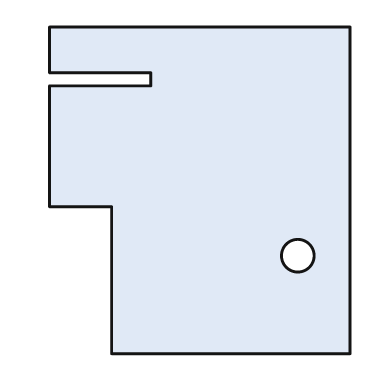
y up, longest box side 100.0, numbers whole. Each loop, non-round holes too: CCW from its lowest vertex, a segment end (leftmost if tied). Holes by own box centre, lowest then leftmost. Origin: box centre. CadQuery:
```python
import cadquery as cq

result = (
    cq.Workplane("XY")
    .moveTo(-27.0, -50.0)
    .lineTo(46.0, -50.0)
    .lineTo(46.0, 50.0)
    .lineTo(-46.0, 50.0)
    .lineTo(-46.0, 36.0)
    .lineTo(-15.0, 36.0)
    .lineTo(-15.0, 32.0)
    .lineTo(-46.0, 32.0)
    .lineTo(-46.0, -5.0)
    .lineTo(-27.0, -5.0)
    .close()
    .moveTo(30.0, -20.0)
    .circle(5.0)
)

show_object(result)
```